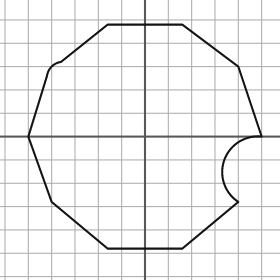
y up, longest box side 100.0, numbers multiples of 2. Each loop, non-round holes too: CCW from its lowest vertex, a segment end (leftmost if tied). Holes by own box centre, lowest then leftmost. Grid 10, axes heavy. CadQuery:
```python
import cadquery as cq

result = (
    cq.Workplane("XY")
    .moveTo(-16.0, -48.0)
    .lineTo(16.0, -48.0)
    .lineTo(40.0, -28.0)
    .threePointArc((34.0, -10.0), (50.0, 0.0))
    .lineTo(40.0, 30.0)
    .lineTo(16.0, 48.0)
    .lineTo(-16.0, 48.0)
    .lineTo(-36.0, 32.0)
    .threePointArc((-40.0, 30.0), (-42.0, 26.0))
    .lineTo(-50.0, 0.0)
    .lineTo(-40.0, -28.0)
    .close()
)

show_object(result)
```